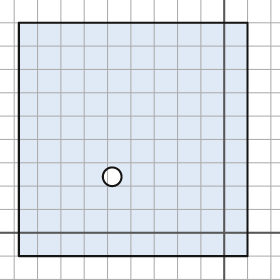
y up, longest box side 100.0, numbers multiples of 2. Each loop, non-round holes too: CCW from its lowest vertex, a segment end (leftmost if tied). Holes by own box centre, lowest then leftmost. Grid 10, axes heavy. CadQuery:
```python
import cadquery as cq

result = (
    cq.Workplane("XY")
    .moveTo(-88.0, -10.0)
    .lineTo(10.0, -10.0)
    .lineTo(10.0, 90.0)
    .lineTo(-88.0, 90.0)
    .close()
    .moveTo(-48.0, 24.0)
    .circle(4.0)
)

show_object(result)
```